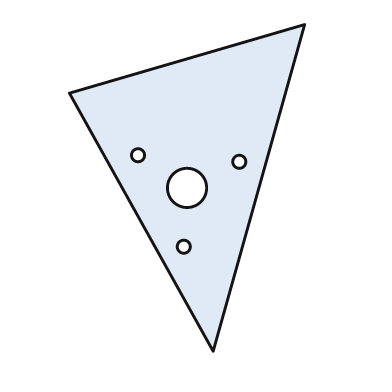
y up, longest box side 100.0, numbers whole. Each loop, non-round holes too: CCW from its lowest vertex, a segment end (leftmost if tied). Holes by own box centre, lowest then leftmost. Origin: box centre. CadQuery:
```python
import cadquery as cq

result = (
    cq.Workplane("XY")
    .moveTo(8.0, -50.0)
    .lineTo(36.0, 50.0)
    .lineTo(-36.0, 29.0)
    .close()
    .moveTo(-1.0, -18.0)
    .circle(2.0)
    .moveTo(0.0, 0.0)
    .circle(6.0)
    .moveTo(16.0, 8.0)
    .circle(2.0)
    .moveTo(-15.0, 10.0)
    .circle(2.0)
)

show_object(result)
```